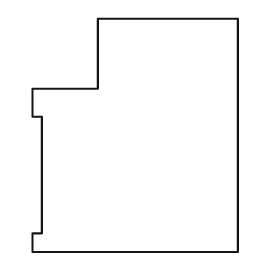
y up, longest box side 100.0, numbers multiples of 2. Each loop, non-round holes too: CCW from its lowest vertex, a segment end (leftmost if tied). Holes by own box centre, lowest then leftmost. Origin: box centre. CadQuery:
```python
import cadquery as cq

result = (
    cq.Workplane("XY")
    .moveTo(-44.0, -50.0)
    .lineTo(44.0, -50.0)
    .lineTo(44.0, 50.0)
    .lineTo(-16.0, 50.0)
    .lineTo(-16.0, 20.0)
    .lineTo(-44.0, 20.0)
    .lineTo(-44.0, 8.0)
    .lineTo(-40.0, 8.0)
    .lineTo(-40.0, -42.0)
    .lineTo(-44.0, -42.0)
    .close()
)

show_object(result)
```